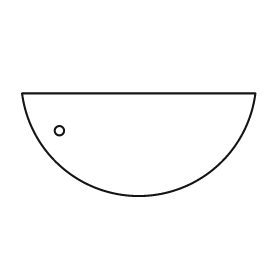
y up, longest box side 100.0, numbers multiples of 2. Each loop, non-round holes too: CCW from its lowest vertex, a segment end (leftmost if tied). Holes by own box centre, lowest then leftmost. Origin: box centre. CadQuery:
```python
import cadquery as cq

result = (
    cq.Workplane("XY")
    .moveTo(-50.0, 22.0)
    .threePointArc((0.0, -22.0), (50.0, 22.0))
    .close()
    .moveTo(-34.0, 6.0)
    .circle(2.0)
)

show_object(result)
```